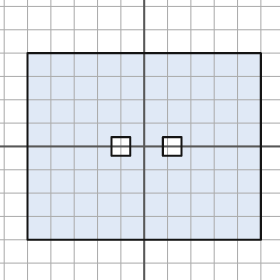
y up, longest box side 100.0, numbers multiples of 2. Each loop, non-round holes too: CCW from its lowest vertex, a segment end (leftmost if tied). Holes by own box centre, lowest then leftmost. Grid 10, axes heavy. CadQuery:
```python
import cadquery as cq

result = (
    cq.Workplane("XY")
    .moveTo(-50.0, -40.0)
    .lineTo(50.0, -40.0)
    .lineTo(50.0, 40.0)
    .lineTo(-50.0, 40.0)
    .close()
    .moveTo(-14.0, -4.0)
    .lineTo(-6.0, -4.0)
    .lineTo(-6.0, 4.0)
    .lineTo(-14.0, 4.0)
    .close()
    .moveTo(8.0, -4.0)
    .lineTo(16.0, -4.0)
    .lineTo(16.0, 4.0)
    .lineTo(8.0, 4.0)
    .close()
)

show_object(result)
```